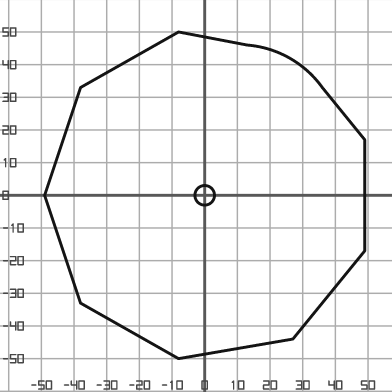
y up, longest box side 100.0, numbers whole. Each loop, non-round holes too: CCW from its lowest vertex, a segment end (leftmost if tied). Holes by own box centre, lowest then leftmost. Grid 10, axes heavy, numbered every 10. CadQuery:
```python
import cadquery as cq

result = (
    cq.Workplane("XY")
    .moveTo(-8.0, -50.0)
    .lineTo(27.0, -44.0)
    .lineTo(49.0, -17.0)
    .lineTo(49.0, 17.0)
    .lineTo(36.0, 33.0)
    .threePointArc((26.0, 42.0), (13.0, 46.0))
    .lineTo(-8.0, 50.0)
    .lineTo(-38.0, 33.0)
    .lineTo(-49.0, 0.0)
    .lineTo(-38.0, -33.0)
    .close()
    .moveTo(0.0, 0.0)
    .circle(3.0)
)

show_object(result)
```